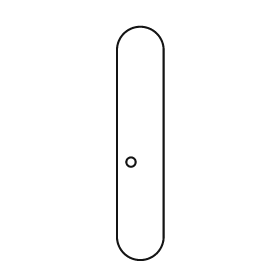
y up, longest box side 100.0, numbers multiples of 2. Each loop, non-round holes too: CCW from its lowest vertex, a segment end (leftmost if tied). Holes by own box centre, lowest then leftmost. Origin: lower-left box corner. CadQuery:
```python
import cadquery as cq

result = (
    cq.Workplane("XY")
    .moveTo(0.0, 10.0)
    .threePointArc((10.0, 0.0), (20.0, 10.0))
    .lineTo(20.0, 90.0)
    .threePointArc((10.0, 100.0), (0.0, 90.0))
    .close()
    .moveTo(6.0, 42.0)
    .circle(2.0)
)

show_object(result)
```